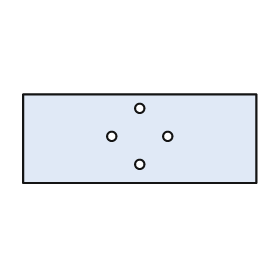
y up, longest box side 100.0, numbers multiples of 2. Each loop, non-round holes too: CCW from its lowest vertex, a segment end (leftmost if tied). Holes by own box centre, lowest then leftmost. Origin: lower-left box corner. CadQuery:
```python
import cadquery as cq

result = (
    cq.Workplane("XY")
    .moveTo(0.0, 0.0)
    .lineTo(100.0, 0.0)
    .lineTo(100.0, 38.0)
    .lineTo(0.0, 38.0)
    .close()
    .moveTo(50.0, 8.0)
    .circle(2.0)
    .moveTo(38.0, 20.0)
    .circle(2.0)
    .moveTo(62.0, 20.0)
    .circle(2.0)
    .moveTo(50.0, 32.0)
    .circle(2.0)
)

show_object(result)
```